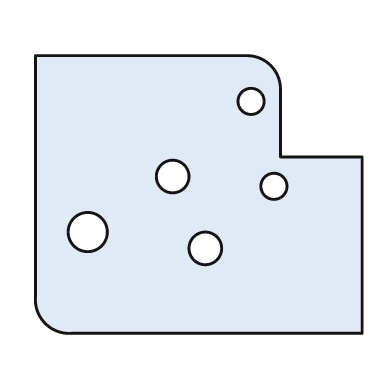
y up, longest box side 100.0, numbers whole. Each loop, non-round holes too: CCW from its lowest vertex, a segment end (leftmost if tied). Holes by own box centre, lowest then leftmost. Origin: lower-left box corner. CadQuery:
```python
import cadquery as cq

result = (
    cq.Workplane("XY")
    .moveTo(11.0, 0.0)
    .lineTo(100.0, 0.0)
    .lineTo(100.0, 54.0)
    .lineTo(75.0, 54.0)
    .lineTo(75.0, 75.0)
    .threePointArc((72.0, 82.0), (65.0, 85.0))
    .lineTo(0.0, 85.0)
    .lineTo(0.0, 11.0)
    .threePointArc((3.0, 3.0), (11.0, 0.0))
    .close()
    .moveTo(52.0, 26.0)
    .circle(5.0)
    .moveTo(16.0, 31.0)
    .circle(6.0)
    .moveTo(73.0, 45.0)
    .circle(4.0)
    .moveTo(42.0, 48.0)
    .circle(5.0)
    .moveTo(66.0, 71.0)
    .circle(4.0)
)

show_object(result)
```